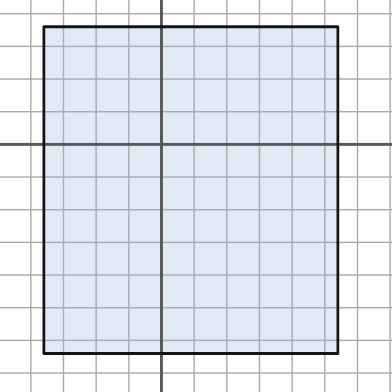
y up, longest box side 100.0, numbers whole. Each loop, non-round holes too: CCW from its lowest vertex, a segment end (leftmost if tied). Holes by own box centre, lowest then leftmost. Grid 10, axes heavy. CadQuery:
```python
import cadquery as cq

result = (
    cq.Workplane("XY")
    .moveTo(-36.0, -64.0)
    .lineTo(54.0, -64.0)
    .lineTo(54.0, 36.0)
    .lineTo(-36.0, 36.0)
    .close()
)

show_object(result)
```